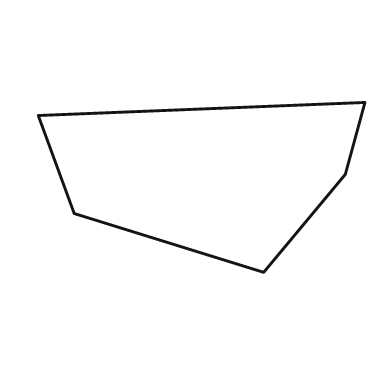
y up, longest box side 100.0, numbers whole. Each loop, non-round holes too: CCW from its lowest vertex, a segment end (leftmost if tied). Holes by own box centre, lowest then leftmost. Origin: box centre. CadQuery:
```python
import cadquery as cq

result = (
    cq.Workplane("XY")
    .moveTo(19.0, -26.0)
    .lineTo(44.0, 4.0)
    .lineTo(50.0, 26.0)
    .lineTo(-50.0, 22.0)
    .lineTo(-39.0, -8.0)
    .close()
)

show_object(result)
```